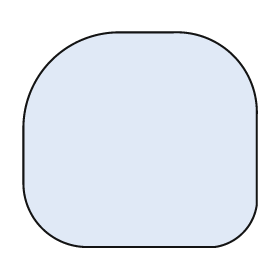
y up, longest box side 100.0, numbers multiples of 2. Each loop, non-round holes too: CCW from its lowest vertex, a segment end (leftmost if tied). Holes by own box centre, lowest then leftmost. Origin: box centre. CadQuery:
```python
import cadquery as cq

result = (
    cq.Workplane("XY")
    .moveTo(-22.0, -46.0)
    .lineTo(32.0, -46.0)
    .threePointArc((44.0, -40.0), (50.0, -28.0))
    .lineTo(50.0, 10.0)
    .threePointArc((40.0, 36.0), (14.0, 46.0))
    .lineTo(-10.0, 46.0)
    .threePointArc((-38.0, 34.0), (-50.0, 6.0))
    .lineTo(-50.0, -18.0)
    .threePointArc((-42.0, -38.0), (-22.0, -46.0))
    .close()
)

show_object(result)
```